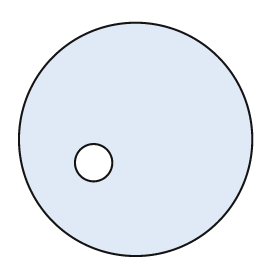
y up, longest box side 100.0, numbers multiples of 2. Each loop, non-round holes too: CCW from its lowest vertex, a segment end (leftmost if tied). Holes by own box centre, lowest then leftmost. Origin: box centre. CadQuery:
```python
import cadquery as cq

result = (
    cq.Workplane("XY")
    .moveTo(0.0, 0.0)
    .circle(50.0)
    .moveTo(-18.0, -10.0)
    .circle(8.0)
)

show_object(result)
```